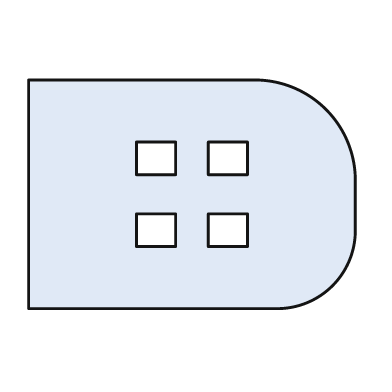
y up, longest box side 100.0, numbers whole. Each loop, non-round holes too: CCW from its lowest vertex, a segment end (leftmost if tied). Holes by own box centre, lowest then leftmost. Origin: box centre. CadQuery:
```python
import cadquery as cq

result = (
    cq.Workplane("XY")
    .moveTo(-50.0, -35.0)
    .lineTo(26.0, -35.0)
    .threePointArc((43.0, -28.0), (50.0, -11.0))
    .lineTo(50.0, 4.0)
    .threePointArc((41.0, 26.0), (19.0, 35.0))
    .lineTo(-50.0, 35.0)
    .close()
    .moveTo(-17.0, -16.0)
    .lineTo(-5.0, -16.0)
    .lineTo(-5.0, -6.0)
    .lineTo(-17.0, -6.0)
    .close()
    .moveTo(5.0, -16.0)
    .lineTo(17.0, -16.0)
    .lineTo(17.0, -6.0)
    .lineTo(5.0, -6.0)
    .close()
    .moveTo(-17.0, 6.0)
    .lineTo(-5.0, 6.0)
    .lineTo(-5.0, 16.0)
    .lineTo(-17.0, 16.0)
    .close()
    .moveTo(5.0, 6.0)
    .lineTo(17.0, 6.0)
    .lineTo(17.0, 16.0)
    .lineTo(5.0, 16.0)
    .close()
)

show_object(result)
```